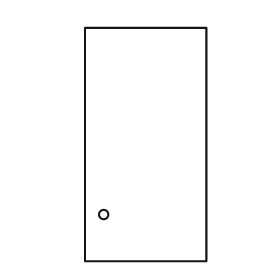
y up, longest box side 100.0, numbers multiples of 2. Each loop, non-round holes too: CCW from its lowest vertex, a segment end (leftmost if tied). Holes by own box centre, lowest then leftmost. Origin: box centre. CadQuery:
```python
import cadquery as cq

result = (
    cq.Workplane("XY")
    .moveTo(-26.0, -50.0)
    .lineTo(26.0, -50.0)
    .lineTo(26.0, 50.0)
    .lineTo(-26.0, 50.0)
    .close()
    .moveTo(-18.0, -30.0)
    .circle(2.0)
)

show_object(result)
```